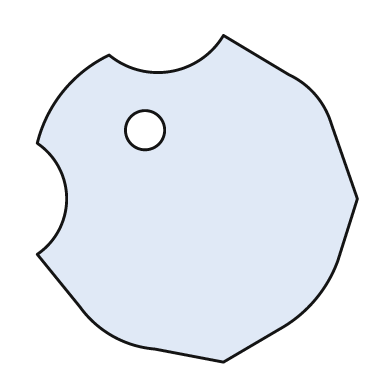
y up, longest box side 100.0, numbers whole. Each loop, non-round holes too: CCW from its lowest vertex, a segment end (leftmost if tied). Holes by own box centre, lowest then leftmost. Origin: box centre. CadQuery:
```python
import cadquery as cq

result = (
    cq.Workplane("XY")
    .moveTo(8.0, -50.0)
    .lineTo(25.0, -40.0)
    .threePointArc((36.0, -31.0), (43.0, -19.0))
    .lineTo(49.0, 0.0)
    .lineTo(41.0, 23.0)
    .threePointArc((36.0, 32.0), (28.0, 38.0))
    .lineTo(8.0, 50.0)
    .threePointArc((-8.0, 39.0), (-27.0, 44.0))
    .threePointArc((-41.0, 33.0), (-49.0, 17.0))
    .threePointArc((-40.0, 0.0), (-49.0, -17.0))
    .lineTo(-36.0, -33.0)
    .threePointArc((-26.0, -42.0), (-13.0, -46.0))
    .close()
    .moveTo(-16.0, 21.0)
    .circle(6.0)
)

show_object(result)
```